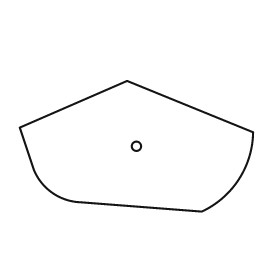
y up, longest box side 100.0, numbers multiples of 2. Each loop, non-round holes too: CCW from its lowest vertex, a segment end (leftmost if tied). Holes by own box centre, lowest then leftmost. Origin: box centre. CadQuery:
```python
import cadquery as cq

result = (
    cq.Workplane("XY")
    .moveTo(28.0, -28.0)
    .threePointArc((44.0, -14.0), (50.0, 6.0))
    .lineTo(-4.0, 28.0)
    .lineTo(-50.0, 8.0)
    .lineTo(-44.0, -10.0)
    .threePointArc((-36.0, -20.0), (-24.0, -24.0))
    .close()
    .moveTo(0.0, 0.0)
    .circle(2.0)
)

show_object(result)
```